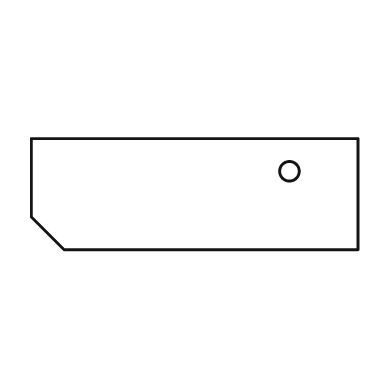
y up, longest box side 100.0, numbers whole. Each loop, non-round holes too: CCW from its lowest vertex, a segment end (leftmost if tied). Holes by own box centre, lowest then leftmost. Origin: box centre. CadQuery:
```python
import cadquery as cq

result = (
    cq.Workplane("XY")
    .moveTo(-40.0, -17.0)
    .lineTo(50.0, -17.0)
    .lineTo(50.0, 17.0)
    .lineTo(-50.0, 17.0)
    .lineTo(-50.0, -7.0)
    .close()
    .moveTo(29.0, 7.0)
    .circle(3.0)
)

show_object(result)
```